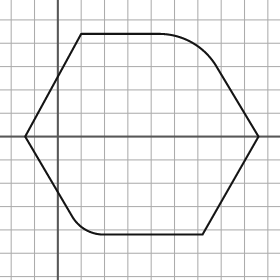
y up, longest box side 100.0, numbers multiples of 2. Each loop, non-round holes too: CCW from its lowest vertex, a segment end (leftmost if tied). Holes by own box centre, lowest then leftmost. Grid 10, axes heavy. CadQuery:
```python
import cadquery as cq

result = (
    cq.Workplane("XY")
    .moveTo(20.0, -42.0)
    .lineTo(62.0, -42.0)
    .lineTo(86.0, 0.0)
    .lineTo(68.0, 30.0)
    .threePointArc((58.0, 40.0), (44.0, 44.0))
    .lineTo(10.0, 44.0)
    .lineTo(-14.0, 0.0)
    .lineTo(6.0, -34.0)
    .threePointArc((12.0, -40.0), (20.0, -42.0))
    .close()
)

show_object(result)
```